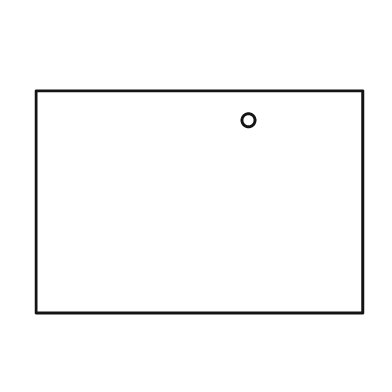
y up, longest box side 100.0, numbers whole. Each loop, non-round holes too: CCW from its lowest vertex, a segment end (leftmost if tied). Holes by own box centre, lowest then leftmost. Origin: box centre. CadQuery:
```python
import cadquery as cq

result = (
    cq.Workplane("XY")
    .moveTo(-50.0, -34.0)
    .lineTo(50.0, -34.0)
    .lineTo(50.0, 34.0)
    .lineTo(-50.0, 34.0)
    .close()
    .moveTo(15.0, 25.0)
    .circle(2.0)
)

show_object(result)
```